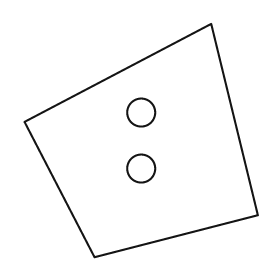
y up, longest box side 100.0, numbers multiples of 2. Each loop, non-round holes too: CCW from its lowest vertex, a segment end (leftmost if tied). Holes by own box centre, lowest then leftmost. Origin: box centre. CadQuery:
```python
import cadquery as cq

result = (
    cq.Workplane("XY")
    .moveTo(-20.0, -50.0)
    .lineTo(50.0, -32.0)
    .lineTo(30.0, 50.0)
    .lineTo(-50.0, 8.0)
    .close()
    .moveTo(0.0, -12.0)
    .circle(6.0)
    .moveTo(0.0, 12.0)
    .circle(6.0)
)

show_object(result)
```